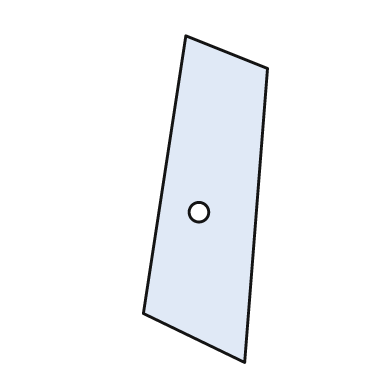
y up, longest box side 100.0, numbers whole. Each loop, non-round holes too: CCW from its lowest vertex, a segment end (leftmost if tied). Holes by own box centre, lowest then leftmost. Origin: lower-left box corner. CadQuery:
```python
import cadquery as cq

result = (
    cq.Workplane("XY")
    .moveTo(31.0, 0.0)
    .lineTo(38.0, 90.0)
    .lineTo(13.0, 100.0)
    .lineTo(0.0, 15.0)
    .close()
    .moveTo(17.0, 46.0)
    .circle(3.0)
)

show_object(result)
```